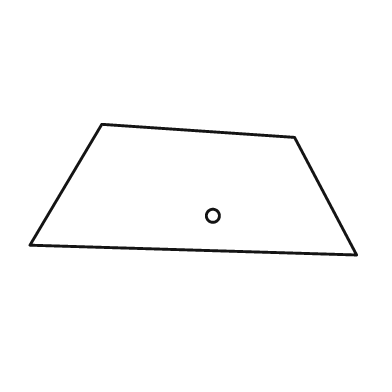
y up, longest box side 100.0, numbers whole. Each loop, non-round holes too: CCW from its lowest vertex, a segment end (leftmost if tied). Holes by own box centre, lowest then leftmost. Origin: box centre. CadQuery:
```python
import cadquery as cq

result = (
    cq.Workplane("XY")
    .moveTo(50.0, -20.0)
    .lineTo(31.0, 16.0)
    .lineTo(-28.0, 20.0)
    .lineTo(-50.0, -17.0)
    .close()
    .moveTo(6.0, -8.0)
    .circle(2.0)
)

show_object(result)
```